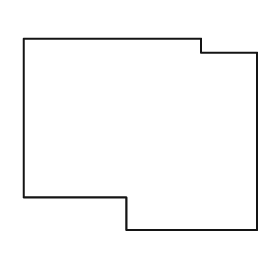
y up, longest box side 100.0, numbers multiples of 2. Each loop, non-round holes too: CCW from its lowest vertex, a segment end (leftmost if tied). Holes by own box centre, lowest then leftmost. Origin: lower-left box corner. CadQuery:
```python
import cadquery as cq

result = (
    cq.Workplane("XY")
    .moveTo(44.0, 0.0)
    .lineTo(100.0, 0.0)
    .lineTo(100.0, 76.0)
    .lineTo(76.0, 76.0)
    .lineTo(76.0, 82.0)
    .lineTo(0.0, 82.0)
    .lineTo(0.0, 14.0)
    .lineTo(44.0, 14.0)
    .close()
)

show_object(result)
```